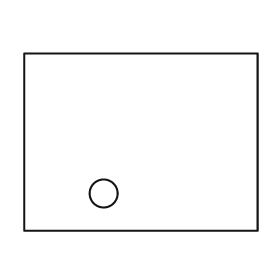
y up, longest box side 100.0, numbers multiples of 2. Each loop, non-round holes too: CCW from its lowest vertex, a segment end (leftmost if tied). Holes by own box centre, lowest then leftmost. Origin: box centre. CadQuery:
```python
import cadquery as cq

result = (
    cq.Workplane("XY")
    .moveTo(-50.0, -38.0)
    .lineTo(50.0, -38.0)
    .lineTo(50.0, 38.0)
    .lineTo(-50.0, 38.0)
    .close()
    .moveTo(-16.0, -22.0)
    .circle(6.0)
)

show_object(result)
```